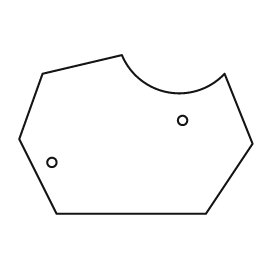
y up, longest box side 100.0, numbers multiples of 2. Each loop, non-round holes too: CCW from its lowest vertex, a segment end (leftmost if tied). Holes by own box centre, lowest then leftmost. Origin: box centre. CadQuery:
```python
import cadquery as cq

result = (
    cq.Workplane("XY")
    .moveTo(-34.0, -34.0)
    .lineTo(30.0, -34.0)
    .lineTo(50.0, -4.0)
    .lineTo(38.0, 26.0)
    .threePointArc((14.0, 18.0), (-6.0, 34.0))
    .lineTo(-40.0, 26.0)
    .lineTo(-50.0, -2.0)
    .close()
    .moveTo(-36.0, -12.0)
    .circle(2.0)
    .moveTo(20.0, 6.0)
    .circle(2.0)
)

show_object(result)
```